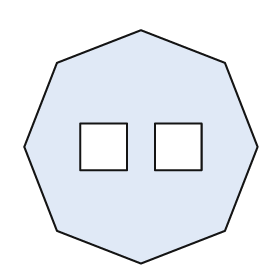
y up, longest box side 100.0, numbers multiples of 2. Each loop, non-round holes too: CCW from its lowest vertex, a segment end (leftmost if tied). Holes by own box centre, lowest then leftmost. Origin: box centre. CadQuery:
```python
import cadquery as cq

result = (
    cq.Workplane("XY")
    .moveTo(0.0, -50.0)
    .lineTo(36.0, -36.0)
    .lineTo(50.0, 0.0)
    .lineTo(36.0, 36.0)
    .lineTo(0.0, 50.0)
    .lineTo(-36.0, 36.0)
    .lineTo(-50.0, 0.0)
    .lineTo(-36.0, -36.0)
    .close()
    .moveTo(-26.0, -10.0)
    .lineTo(-6.0, -10.0)
    .lineTo(-6.0, 10.0)
    .lineTo(-26.0, 10.0)
    .close()
    .moveTo(6.0, -10.0)
    .lineTo(26.0, -10.0)
    .lineTo(26.0, 10.0)
    .lineTo(6.0, 10.0)
    .close()
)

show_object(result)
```